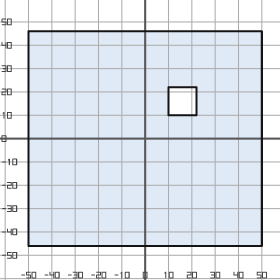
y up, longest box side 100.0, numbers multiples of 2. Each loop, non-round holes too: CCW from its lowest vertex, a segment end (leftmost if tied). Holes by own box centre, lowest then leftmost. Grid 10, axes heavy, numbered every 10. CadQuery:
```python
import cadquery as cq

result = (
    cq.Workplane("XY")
    .moveTo(-50.0, -46.0)
    .lineTo(50.0, -46.0)
    .lineTo(50.0, 46.0)
    .lineTo(-50.0, 46.0)
    .close()
    .moveTo(10.0, 10.0)
    .lineTo(22.0, 10.0)
    .lineTo(22.0, 22.0)
    .lineTo(10.0, 22.0)
    .close()
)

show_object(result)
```